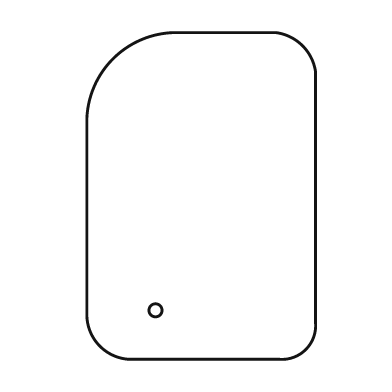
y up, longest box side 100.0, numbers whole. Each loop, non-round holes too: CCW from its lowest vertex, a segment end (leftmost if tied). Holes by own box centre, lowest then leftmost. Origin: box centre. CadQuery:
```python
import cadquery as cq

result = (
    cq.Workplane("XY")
    .moveTo(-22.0, -50.0)
    .lineTo(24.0, -50.0)
    .threePointArc((32.0, -47.0), (35.0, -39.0))
    .lineTo(35.0, 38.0)
    .threePointArc((31.0, 46.0), (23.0, 50.0))
    .lineTo(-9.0, 50.0)
    .threePointArc((-27.0, 42.0), (-35.0, 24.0))
    .lineTo(-35.0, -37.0)
    .threePointArc((-31.0, -46.0), (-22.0, -50.0))
    .close()
    .moveTo(-14.0, -35.0)
    .circle(2.0)
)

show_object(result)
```